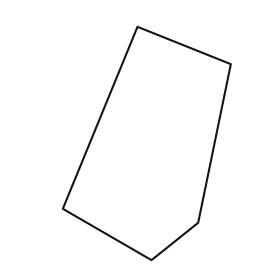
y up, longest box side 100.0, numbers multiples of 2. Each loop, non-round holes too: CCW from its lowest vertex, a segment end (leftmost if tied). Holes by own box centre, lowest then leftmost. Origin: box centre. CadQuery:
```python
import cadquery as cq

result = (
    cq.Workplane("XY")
    .moveTo(2.0, -50.0)
    .lineTo(22.0, -34.0)
    .lineTo(36.0, 34.0)
    .lineTo(-4.0, 50.0)
    .lineTo(-36.0, -28.0)
    .close()
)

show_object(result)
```